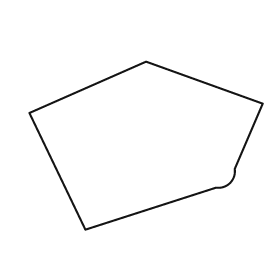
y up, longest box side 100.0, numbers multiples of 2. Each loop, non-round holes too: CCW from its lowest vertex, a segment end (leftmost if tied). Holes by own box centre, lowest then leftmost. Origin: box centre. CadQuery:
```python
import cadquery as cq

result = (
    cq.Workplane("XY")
    .moveTo(-26.0, -36.0)
    .lineTo(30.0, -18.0)
    .threePointArc((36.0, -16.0), (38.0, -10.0))
    .lineTo(50.0, 18.0)
    .lineTo(0.0, 36.0)
    .lineTo(-50.0, 14.0)
    .close()
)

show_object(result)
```